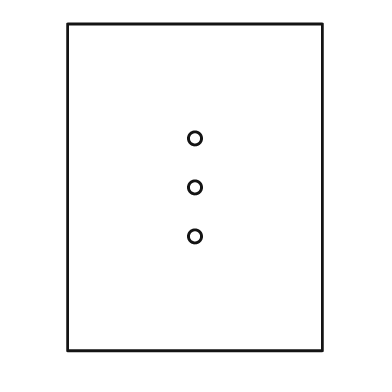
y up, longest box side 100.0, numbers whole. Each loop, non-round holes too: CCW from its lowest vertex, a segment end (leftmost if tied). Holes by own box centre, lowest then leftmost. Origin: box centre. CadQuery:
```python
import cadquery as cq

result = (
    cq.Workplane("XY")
    .moveTo(-39.0, -50.0)
    .lineTo(39.0, -50.0)
    .lineTo(39.0, 50.0)
    .lineTo(-39.0, 50.0)
    .close()
    .moveTo(0.0, -15.0)
    .circle(2.0)
    .moveTo(0.0, 0.0)
    .circle(2.0)
    .moveTo(0.0, 15.0)
    .circle(2.0)
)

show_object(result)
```